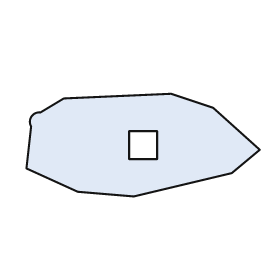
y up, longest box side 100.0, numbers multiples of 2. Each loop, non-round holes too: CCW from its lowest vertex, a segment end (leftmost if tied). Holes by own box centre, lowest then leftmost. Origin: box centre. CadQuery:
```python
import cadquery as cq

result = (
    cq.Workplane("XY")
    .moveTo(-4.0, -22.0)
    .lineTo(38.0, -12.0)
    .lineTo(50.0, -2.0)
    .lineTo(30.0, 16.0)
    .lineTo(12.0, 22.0)
    .lineTo(-34.0, 20.0)
    .lineTo(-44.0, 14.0)
    .threePointArc((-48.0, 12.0), (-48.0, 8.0))
    .lineTo(-50.0, -10.0)
    .lineTo(-28.0, -20.0)
    .close()
    .moveTo(-6.0, -6.0)
    .lineTo(6.0, -6.0)
    .lineTo(6.0, 6.0)
    .lineTo(-6.0, 6.0)
    .close()
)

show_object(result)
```